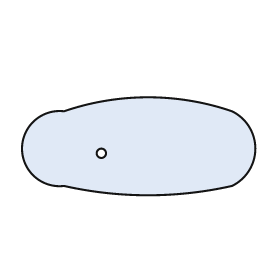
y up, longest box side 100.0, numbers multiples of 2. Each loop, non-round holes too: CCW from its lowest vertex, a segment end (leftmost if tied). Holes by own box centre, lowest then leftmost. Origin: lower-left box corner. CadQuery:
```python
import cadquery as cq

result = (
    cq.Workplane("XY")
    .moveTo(18.0, 4.0)
    .threePointArc((54.0, 0.0), (90.0, 4.0))
    .threePointArc((100.0, 20.0), (90.0, 36.0))
    .threePointArc((54.0, 42.0), (18.0, 36.0))
    .threePointArc((0.0, 20.0), (18.0, 4.0))
    .close()
    .moveTo(34.0, 18.0)
    .circle(2.0)
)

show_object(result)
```